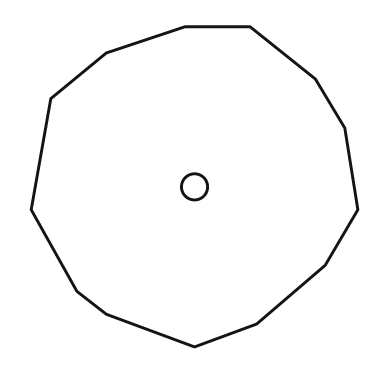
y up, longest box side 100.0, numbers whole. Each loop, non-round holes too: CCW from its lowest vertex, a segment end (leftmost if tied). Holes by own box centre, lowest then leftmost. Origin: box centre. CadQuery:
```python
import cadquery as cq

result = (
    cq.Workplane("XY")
    .moveTo(0.0, -49.0)
    .lineTo(19.0, -42.0)
    .lineTo(40.0, -24.0)
    .lineTo(50.0, -7.0)
    .lineTo(46.0, 18.0)
    .lineTo(37.0, 33.0)
    .lineTo(17.0, 49.0)
    .lineTo(-3.0, 49.0)
    .lineTo(-27.0, 41.0)
    .lineTo(-44.0, 27.0)
    .lineTo(-50.0, -7.0)
    .lineTo(-36.0, -32.0)
    .lineTo(-27.0, -39.0)
    .close()
    .moveTo(0.0, 0.0)
    .circle(4.0)
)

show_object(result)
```